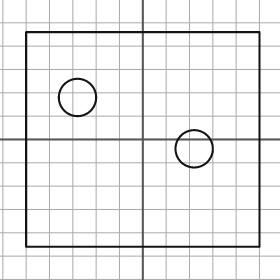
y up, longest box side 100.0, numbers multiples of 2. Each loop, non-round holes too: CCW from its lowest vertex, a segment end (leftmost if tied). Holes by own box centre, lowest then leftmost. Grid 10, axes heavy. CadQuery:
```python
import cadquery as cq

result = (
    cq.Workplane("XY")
    .moveTo(-50.0, -46.0)
    .lineTo(50.0, -46.0)
    .lineTo(50.0, 46.0)
    .lineTo(-50.0, 46.0)
    .close()
    .moveTo(22.0, -4.0)
    .circle(8.0)
    .moveTo(-28.0, 18.0)
    .circle(8.0)
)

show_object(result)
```